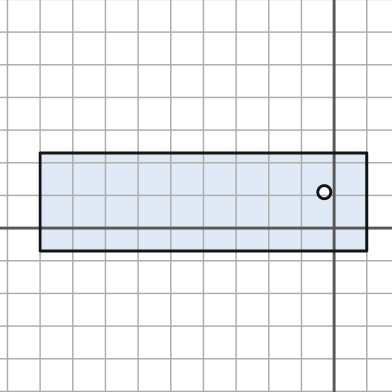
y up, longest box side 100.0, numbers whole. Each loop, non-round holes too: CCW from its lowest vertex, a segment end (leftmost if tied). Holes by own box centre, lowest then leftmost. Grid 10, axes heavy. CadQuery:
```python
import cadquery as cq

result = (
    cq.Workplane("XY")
    .moveTo(-90.0, -7.0)
    .lineTo(10.0, -7.0)
    .lineTo(10.0, 23.0)
    .lineTo(-90.0, 23.0)
    .close()
    .moveTo(-3.0, 11.0)
    .circle(2.0)
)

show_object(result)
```